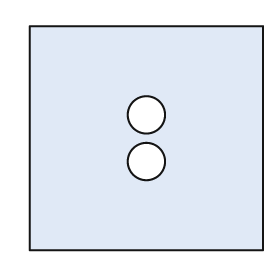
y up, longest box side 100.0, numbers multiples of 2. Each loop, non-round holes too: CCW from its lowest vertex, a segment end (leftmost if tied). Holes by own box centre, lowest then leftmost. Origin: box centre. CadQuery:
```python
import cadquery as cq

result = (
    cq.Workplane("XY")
    .moveTo(-50.0, -48.0)
    .lineTo(50.0, -48.0)
    .lineTo(50.0, 48.0)
    .lineTo(-50.0, 48.0)
    .close()
    .moveTo(0.0, -10.0)
    .circle(8.0)
    .moveTo(0.0, 10.0)
    .circle(8.0)
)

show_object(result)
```